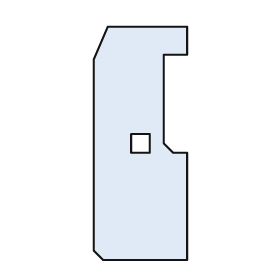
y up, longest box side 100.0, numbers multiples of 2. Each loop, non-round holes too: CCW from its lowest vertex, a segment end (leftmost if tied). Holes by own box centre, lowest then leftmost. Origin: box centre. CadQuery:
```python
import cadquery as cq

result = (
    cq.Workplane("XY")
    .moveTo(-16.0, -50.0)
    .lineTo(20.0, -50.0)
    .lineTo(20.0, -4.0)
    .lineTo(14.0, -4.0)
    .lineTo(10.0, 0.0)
    .lineTo(10.0, 38.0)
    .lineTo(20.0, 38.0)
    .lineTo(20.0, 50.0)
    .lineTo(-14.0, 50.0)
    .lineTo(-20.0, 36.0)
    .lineTo(-20.0, -46.0)
    .close()
    .moveTo(-4.0, -4.0)
    .lineTo(4.0, -4.0)
    .lineTo(4.0, 4.0)
    .lineTo(-4.0, 4.0)
    .close()
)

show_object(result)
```